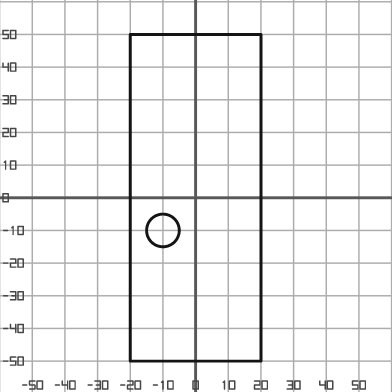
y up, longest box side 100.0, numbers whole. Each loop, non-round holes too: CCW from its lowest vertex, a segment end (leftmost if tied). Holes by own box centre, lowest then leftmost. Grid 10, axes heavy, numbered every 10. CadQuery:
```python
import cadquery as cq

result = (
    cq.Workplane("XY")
    .moveTo(-20.0, -50.0)
    .lineTo(20.0, -50.0)
    .lineTo(20.0, 50.0)
    .lineTo(-20.0, 50.0)
    .close()
    .moveTo(-10.0, -10.0)
    .circle(5.0)
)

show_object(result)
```